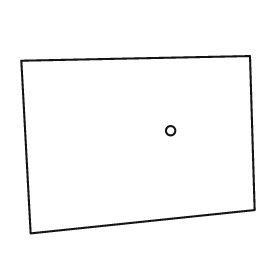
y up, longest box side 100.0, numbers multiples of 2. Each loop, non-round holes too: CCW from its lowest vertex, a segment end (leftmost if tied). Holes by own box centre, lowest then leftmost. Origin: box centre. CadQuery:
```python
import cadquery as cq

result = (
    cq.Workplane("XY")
    .moveTo(-46.0, -38.0)
    .lineTo(50.0, -28.0)
    .lineTo(48.0, 38.0)
    .lineTo(-50.0, 36.0)
    .close()
    .moveTo(14.0, 6.0)
    .circle(2.0)
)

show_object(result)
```